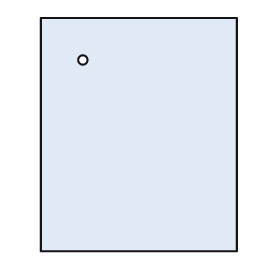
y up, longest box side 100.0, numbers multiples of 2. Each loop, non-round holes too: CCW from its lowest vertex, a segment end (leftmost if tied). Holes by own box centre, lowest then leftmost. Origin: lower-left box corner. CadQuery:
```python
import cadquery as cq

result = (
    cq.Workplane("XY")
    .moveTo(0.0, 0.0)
    .lineTo(84.0, 0.0)
    .lineTo(84.0, 100.0)
    .lineTo(0.0, 100.0)
    .close()
    .moveTo(18.0, 82.0)
    .circle(2.0)
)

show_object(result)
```